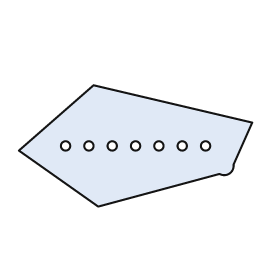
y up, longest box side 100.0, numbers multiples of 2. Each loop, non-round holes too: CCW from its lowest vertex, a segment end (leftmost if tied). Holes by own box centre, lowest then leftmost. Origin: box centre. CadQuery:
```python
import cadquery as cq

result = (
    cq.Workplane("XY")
    .moveTo(-16.0, -26.0)
    .lineTo(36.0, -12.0)
    .threePointArc((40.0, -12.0), (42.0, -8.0))
    .lineTo(50.0, 10.0)
    .lineTo(-18.0, 26.0)
    .lineTo(-50.0, -2.0)
    .close()
    .moveTo(-30.0, 0.0)
    .circle(2.0)
    .moveTo(-20.0, 0.0)
    .circle(2.0)
    .moveTo(-10.0, 0.0)
    .circle(2.0)
    .moveTo(0.0, 0.0)
    .circle(2.0)
    .moveTo(10.0, 0.0)
    .circle(2.0)
    .moveTo(20.0, 0.0)
    .circle(2.0)
    .moveTo(30.0, 0.0)
    .circle(2.0)
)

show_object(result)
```